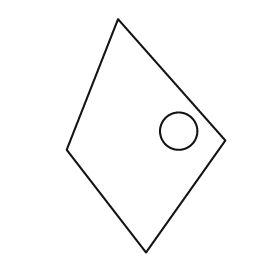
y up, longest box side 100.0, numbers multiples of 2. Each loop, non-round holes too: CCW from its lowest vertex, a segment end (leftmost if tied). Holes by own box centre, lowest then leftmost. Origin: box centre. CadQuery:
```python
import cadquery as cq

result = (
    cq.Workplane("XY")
    .moveTo(0.0, -50.0)
    .lineTo(34.0, -2.0)
    .lineTo(-12.0, 50.0)
    .lineTo(-34.0, -6.0)
    .close()
    .moveTo(14.0, 2.0)
    .circle(8.0)
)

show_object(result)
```